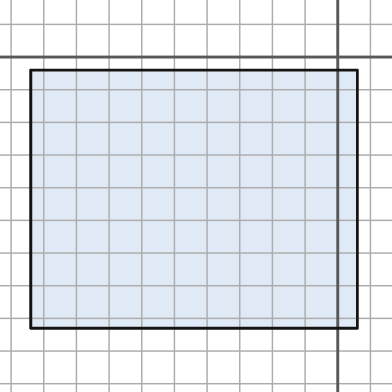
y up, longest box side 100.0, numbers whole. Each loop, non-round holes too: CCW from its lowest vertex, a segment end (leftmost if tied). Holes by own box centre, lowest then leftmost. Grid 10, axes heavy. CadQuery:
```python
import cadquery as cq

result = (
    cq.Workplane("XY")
    .moveTo(-94.0, -83.0)
    .lineTo(6.0, -83.0)
    .lineTo(6.0, -4.0)
    .lineTo(-94.0, -4.0)
    .close()
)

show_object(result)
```